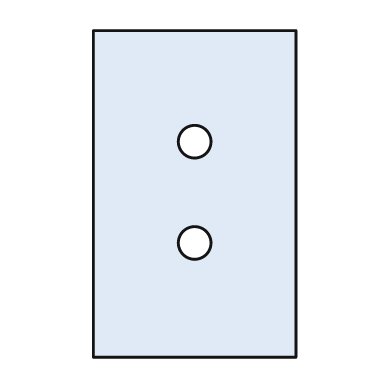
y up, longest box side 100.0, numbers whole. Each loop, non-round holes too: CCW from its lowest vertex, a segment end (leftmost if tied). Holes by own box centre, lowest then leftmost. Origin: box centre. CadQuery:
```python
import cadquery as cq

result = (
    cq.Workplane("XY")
    .moveTo(-31.0, -50.0)
    .lineTo(31.0, -50.0)
    .lineTo(31.0, 50.0)
    .lineTo(-31.0, 50.0)
    .close()
    .moveTo(0.0, -15.0)
    .circle(5.0)
    .moveTo(0.0, 16.0)
    .circle(5.0)
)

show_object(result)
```